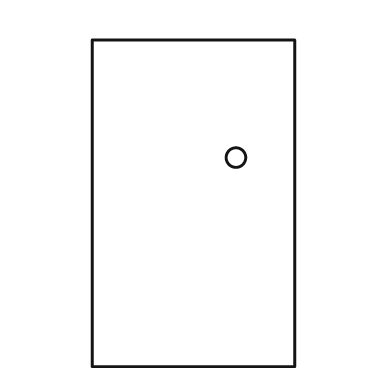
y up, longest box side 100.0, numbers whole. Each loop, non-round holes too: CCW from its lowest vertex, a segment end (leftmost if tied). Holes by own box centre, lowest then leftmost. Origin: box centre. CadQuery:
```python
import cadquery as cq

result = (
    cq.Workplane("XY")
    .moveTo(-31.0, -50.0)
    .lineTo(31.0, -50.0)
    .lineTo(31.0, 50.0)
    .lineTo(-31.0, 50.0)
    .close()
    .moveTo(13.0, 14.0)
    .circle(3.0)
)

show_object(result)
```